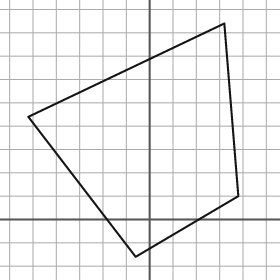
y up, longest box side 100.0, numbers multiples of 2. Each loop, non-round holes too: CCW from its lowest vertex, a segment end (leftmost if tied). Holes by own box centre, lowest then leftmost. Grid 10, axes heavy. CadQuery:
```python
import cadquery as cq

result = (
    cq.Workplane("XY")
    .moveTo(-6.0, -16.0)
    .lineTo(38.0, 10.0)
    .lineTo(32.0, 84.0)
    .lineTo(-52.0, 44.0)
    .close()
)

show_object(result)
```